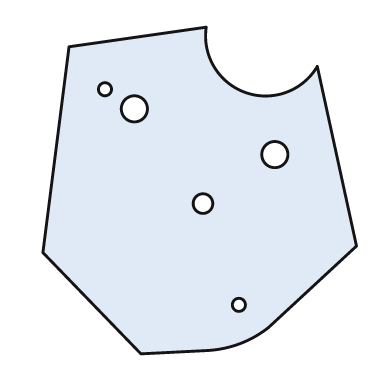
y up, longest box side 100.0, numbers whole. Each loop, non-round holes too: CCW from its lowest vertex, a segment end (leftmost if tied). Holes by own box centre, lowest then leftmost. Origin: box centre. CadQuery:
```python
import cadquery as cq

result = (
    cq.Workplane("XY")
    .moveTo(-18.0, -50.0)
    .lineTo(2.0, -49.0)
    .threePointArc((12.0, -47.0), (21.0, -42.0))
    .lineTo(48.0, -17.0)
    .lineTo(36.0, 38.0)
    .threePointArc((14.0, 30.0), (2.0, 50.0))
    .lineTo(-40.0, 44.0)
    .lineTo(-48.0, -19.0)
    .close()
    .moveTo(12.0, -35.0)
    .circle(2.0)
    .moveTo(1.0, -4.0)
    .circle(3.0)
    .moveTo(23.0, 11.0)
    .circle(4.0)
    .moveTo(-20.0, 25.0)
    .circle(4.0)
    .moveTo(-29.0, 31.0)
    .circle(2.0)
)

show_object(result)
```